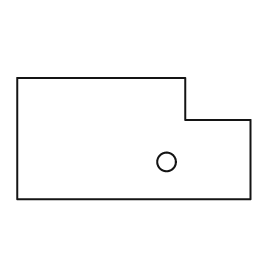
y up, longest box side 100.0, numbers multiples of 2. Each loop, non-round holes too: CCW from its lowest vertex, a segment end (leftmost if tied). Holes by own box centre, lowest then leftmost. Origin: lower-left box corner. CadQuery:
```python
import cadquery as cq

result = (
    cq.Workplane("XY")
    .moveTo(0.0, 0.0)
    .lineTo(100.0, 0.0)
    .lineTo(100.0, 34.0)
    .lineTo(72.0, 34.0)
    .lineTo(72.0, 52.0)
    .lineTo(0.0, 52.0)
    .close()
    .moveTo(64.0, 16.0)
    .circle(4.0)
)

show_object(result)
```